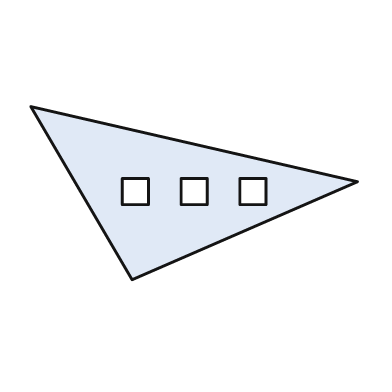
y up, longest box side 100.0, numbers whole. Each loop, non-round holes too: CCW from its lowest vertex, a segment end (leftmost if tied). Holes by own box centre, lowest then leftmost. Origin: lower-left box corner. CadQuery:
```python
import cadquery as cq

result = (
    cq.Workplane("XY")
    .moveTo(31.0, 0.0)
    .lineTo(100.0, 30.0)
    .lineTo(0.0, 53.0)
    .close()
    .moveTo(28.0, 23.0)
    .lineTo(36.0, 23.0)
    .lineTo(36.0, 31.0)
    .lineTo(28.0, 31.0)
    .close()
    .moveTo(46.0, 23.0)
    .lineTo(54.0, 23.0)
    .lineTo(54.0, 31.0)
    .lineTo(46.0, 31.0)
    .close()
    .moveTo(64.0, 23.0)
    .lineTo(72.0, 23.0)
    .lineTo(72.0, 31.0)
    .lineTo(64.0, 31.0)
    .close()
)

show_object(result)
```